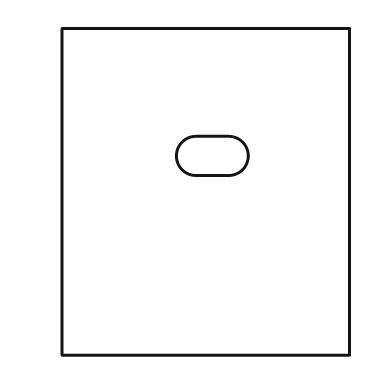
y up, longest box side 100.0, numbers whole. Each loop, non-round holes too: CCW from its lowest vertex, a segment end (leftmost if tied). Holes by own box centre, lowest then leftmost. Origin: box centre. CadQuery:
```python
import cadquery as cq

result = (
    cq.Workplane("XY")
    .moveTo(-44.0, -50.0)
    .lineTo(44.0, -50.0)
    .lineTo(44.0, 50.0)
    .lineTo(-44.0, 50.0)
    .close()
    .moveTo(-3.0, 5.0)
    .lineTo(7.0, 5.0)
    .threePointArc((13.0, 11.0), (7.0, 17.0))
    .lineTo(-3.0, 17.0)
    .threePointArc((-9.0, 11.0), (-3.0, 5.0))
    .close()
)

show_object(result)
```